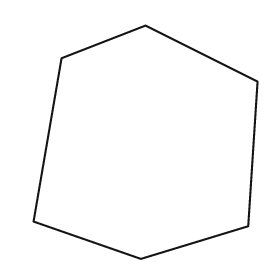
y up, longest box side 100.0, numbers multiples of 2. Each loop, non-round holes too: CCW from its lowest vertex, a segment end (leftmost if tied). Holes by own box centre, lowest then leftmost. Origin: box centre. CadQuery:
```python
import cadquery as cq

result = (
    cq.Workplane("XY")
    .moveTo(-2.0, -50.0)
    .lineTo(44.0, -36.0)
    .lineTo(48.0, 26.0)
    .lineTo(0.0, 50.0)
    .lineTo(-36.0, 36.0)
    .lineTo(-48.0, -34.0)
    .close()
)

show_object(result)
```